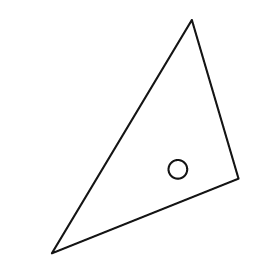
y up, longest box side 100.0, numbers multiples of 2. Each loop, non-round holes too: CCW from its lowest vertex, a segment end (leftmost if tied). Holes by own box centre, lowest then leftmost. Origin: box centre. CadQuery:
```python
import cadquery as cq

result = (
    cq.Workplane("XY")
    .moveTo(-40.0, -50.0)
    .lineTo(40.0, -18.0)
    .lineTo(20.0, 50.0)
    .close()
    .moveTo(14.0, -14.0)
    .circle(4.0)
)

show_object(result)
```